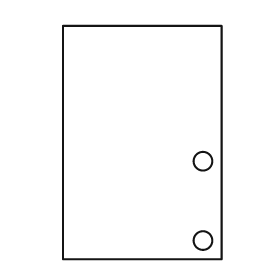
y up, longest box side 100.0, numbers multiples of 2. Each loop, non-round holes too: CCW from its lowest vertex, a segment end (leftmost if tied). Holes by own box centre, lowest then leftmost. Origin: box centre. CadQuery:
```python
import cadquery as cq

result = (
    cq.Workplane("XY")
    .moveTo(-34.0, -50.0)
    .lineTo(34.0, -50.0)
    .lineTo(34.0, 50.0)
    .lineTo(-34.0, 50.0)
    .close()
    .moveTo(26.0, -42.0)
    .circle(4.0)
    .moveTo(26.0, -8.0)
    .circle(4.0)
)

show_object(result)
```